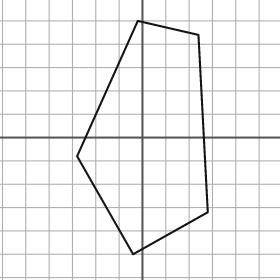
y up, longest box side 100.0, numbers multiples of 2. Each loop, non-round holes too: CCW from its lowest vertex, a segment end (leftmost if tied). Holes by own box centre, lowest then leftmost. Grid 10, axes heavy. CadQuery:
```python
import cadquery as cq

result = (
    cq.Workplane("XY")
    .moveTo(-4.0, -50.0)
    .lineTo(28.0, -32.0)
    .lineTo(24.0, 44.0)
    .lineTo(-2.0, 50.0)
    .lineTo(-28.0, -8.0)
    .close()
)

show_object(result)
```